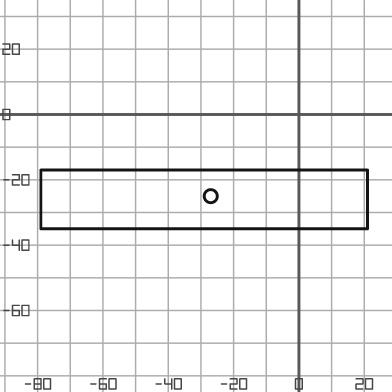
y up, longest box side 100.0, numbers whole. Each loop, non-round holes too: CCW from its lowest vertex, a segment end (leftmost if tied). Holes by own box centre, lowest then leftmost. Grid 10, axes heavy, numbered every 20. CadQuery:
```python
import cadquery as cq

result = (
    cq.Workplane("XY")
    .moveTo(-79.0, -35.0)
    .lineTo(21.0, -35.0)
    .lineTo(21.0, -17.0)
    .lineTo(-79.0, -17.0)
    .close()
    .moveTo(-27.0, -25.0)
    .circle(2.0)
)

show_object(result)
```